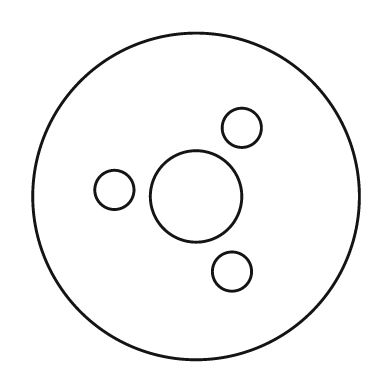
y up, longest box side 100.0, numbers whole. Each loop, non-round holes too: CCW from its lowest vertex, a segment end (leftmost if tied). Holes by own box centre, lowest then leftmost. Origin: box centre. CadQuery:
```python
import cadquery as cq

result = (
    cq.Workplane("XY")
    .moveTo(0.0, 0.0)
    .circle(50.0)
    .moveTo(11.0, -23.0)
    .circle(6.0)
    .moveTo(0.0, 0.0)
    .circle(14.0)
    .moveTo(-25.0, 2.0)
    .circle(6.0)
    .moveTo(14.0, 21.0)
    .circle(6.0)
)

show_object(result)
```